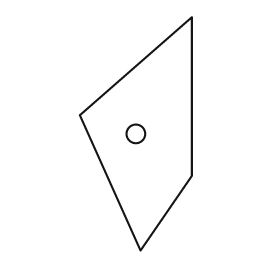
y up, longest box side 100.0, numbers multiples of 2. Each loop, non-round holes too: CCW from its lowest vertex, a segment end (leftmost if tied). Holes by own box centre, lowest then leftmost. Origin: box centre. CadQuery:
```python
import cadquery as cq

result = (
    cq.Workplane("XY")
    .moveTo(2.0, -50.0)
    .lineTo(24.0, -18.0)
    .lineTo(24.0, 50.0)
    .lineTo(-24.0, 8.0)
    .close()
    .moveTo(0.0, 0.0)
    .circle(4.0)
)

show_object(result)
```